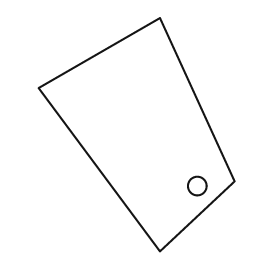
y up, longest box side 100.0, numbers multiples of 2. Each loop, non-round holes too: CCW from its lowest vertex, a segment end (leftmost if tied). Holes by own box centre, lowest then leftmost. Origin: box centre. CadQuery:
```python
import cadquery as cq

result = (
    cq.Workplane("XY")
    .moveTo(10.0, -50.0)
    .lineTo(42.0, -20.0)
    .lineTo(10.0, 50.0)
    .lineTo(-42.0, 20.0)
    .close()
    .moveTo(26.0, -22.0)
    .circle(4.0)
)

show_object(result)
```